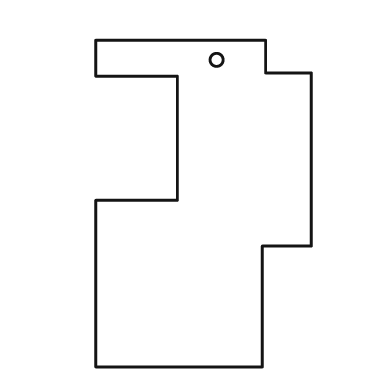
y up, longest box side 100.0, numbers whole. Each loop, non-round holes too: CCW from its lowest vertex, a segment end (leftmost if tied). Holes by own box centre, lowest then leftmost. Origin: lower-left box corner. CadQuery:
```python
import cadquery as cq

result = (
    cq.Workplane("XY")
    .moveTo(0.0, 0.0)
    .lineTo(51.0, 0.0)
    .lineTo(51.0, 37.0)
    .lineTo(66.0, 37.0)
    .lineTo(66.0, 90.0)
    .lineTo(52.0, 90.0)
    .lineTo(52.0, 100.0)
    .lineTo(0.0, 100.0)
    .lineTo(0.0, 89.0)
    .lineTo(25.0, 89.0)
    .lineTo(25.0, 51.0)
    .lineTo(0.0, 51.0)
    .close()
    .moveTo(37.0, 94.0)
    .circle(2.0)
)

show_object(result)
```